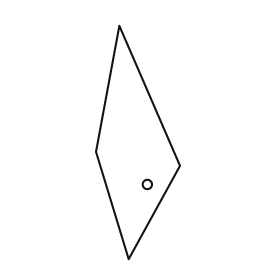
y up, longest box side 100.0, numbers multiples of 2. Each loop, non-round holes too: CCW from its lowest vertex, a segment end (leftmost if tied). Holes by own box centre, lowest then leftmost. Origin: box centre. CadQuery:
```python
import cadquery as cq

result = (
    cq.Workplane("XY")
    .moveTo(-4.0, -50.0)
    .lineTo(18.0, -10.0)
    .lineTo(-8.0, 50.0)
    .lineTo(-18.0, -4.0)
    .close()
    .moveTo(4.0, -18.0)
    .circle(2.0)
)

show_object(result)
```